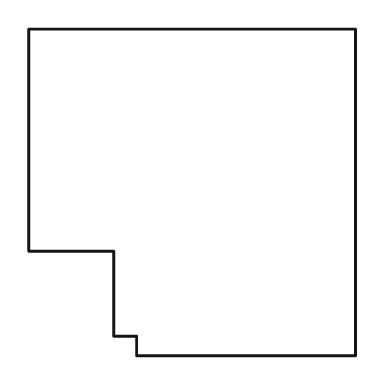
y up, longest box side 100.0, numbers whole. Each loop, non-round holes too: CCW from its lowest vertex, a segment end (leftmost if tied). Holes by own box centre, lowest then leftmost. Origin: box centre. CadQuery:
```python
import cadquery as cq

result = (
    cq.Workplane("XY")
    .moveTo(-17.0, -50.0)
    .lineTo(50.0, -50.0)
    .lineTo(50.0, 50.0)
    .lineTo(-50.0, 50.0)
    .lineTo(-50.0, -18.0)
    .lineTo(-24.0, -18.0)
    .lineTo(-24.0, -44.0)
    .lineTo(-17.0, -44.0)
    .close()
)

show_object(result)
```